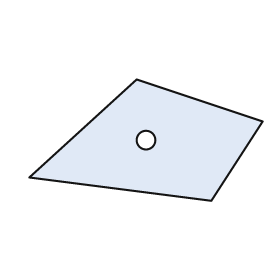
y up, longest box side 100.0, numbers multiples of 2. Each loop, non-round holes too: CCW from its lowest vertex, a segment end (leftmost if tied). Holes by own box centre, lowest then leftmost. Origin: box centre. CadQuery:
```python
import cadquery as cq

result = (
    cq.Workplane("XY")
    .moveTo(28.0, -26.0)
    .lineTo(50.0, 8.0)
    .lineTo(-4.0, 26.0)
    .lineTo(-50.0, -16.0)
    .close()
    .moveTo(0.0, 0.0)
    .circle(4.0)
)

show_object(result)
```